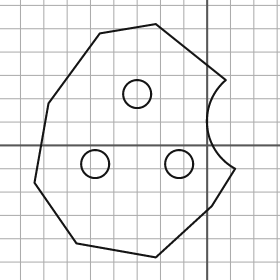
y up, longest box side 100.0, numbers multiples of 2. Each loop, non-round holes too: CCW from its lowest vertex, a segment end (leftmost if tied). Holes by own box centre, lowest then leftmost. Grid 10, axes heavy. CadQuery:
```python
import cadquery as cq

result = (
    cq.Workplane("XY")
    .moveTo(-22.0, -48.0)
    .lineTo(2.0, -26.0)
    .lineTo(12.0, -10.0)
    .threePointArc((0.0, 8.0), (8.0, 28.0))
    .lineTo(-22.0, 52.0)
    .lineTo(-46.0, 48.0)
    .lineTo(-68.0, 18.0)
    .lineTo(-74.0, -16.0)
    .lineTo(-56.0, -42.0)
    .close()
    .moveTo(-48.0, -8.0)
    .circle(6.0)
    .moveTo(-12.0, -8.0)
    .circle(6.0)
    .moveTo(-30.0, 22.0)
    .circle(6.0)
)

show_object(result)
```